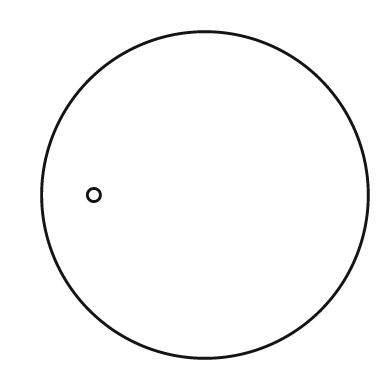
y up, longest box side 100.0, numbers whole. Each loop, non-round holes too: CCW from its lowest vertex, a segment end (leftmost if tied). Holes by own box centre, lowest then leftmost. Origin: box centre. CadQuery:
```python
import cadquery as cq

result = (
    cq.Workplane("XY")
    .moveTo(0.0, 0.0)
    .circle(50.0)
    .moveTo(-34.0, 0.0)
    .circle(2.0)
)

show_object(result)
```